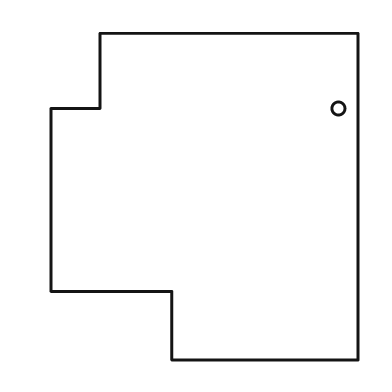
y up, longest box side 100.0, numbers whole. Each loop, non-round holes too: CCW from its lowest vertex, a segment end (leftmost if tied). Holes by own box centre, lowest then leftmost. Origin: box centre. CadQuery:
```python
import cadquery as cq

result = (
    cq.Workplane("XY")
    .moveTo(-10.0, -50.0)
    .lineTo(47.0, -50.0)
    .lineTo(47.0, 50.0)
    .lineTo(-32.0, 50.0)
    .lineTo(-32.0, 27.0)
    .lineTo(-47.0, 27.0)
    .lineTo(-47.0, -29.0)
    .lineTo(-10.0, -29.0)
    .close()
    .moveTo(41.0, 27.0)
    .circle(2.0)
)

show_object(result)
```